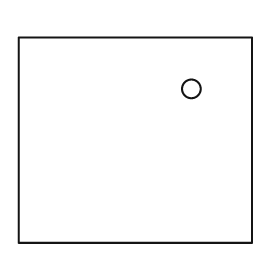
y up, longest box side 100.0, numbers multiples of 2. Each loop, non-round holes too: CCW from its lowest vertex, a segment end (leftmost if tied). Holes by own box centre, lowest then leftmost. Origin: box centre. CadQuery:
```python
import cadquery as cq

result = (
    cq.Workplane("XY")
    .moveTo(-50.0, -44.0)
    .lineTo(50.0, -44.0)
    .lineTo(50.0, 44.0)
    .lineTo(-50.0, 44.0)
    .close()
    .moveTo(24.0, 22.0)
    .circle(4.0)
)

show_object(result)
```